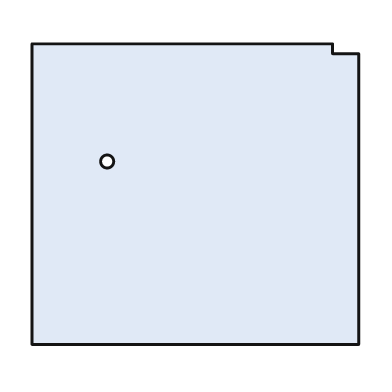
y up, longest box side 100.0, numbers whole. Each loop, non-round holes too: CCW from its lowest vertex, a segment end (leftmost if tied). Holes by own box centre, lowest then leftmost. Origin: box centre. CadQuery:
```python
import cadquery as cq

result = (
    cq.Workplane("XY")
    .moveTo(-50.0, -46.0)
    .lineTo(50.0, -46.0)
    .lineTo(50.0, 43.0)
    .lineTo(42.0, 43.0)
    .lineTo(42.0, 46.0)
    .lineTo(-50.0, 46.0)
    .close()
    .moveTo(-27.0, 10.0)
    .circle(2.0)
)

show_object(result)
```